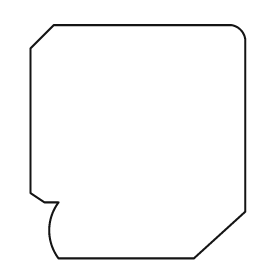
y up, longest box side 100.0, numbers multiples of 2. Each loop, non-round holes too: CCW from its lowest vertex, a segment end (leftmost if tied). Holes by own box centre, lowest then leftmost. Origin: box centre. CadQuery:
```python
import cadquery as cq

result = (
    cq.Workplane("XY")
    .moveTo(-34.0, -50.0)
    .lineTo(24.0, -50.0)
    .lineTo(46.0, -30.0)
    .lineTo(46.0, 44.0)
    .threePointArc((44.0, 48.0), (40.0, 50.0))
    .lineTo(-36.0, 50.0)
    .lineTo(-46.0, 40.0)
    .lineTo(-46.0, -22.0)
    .lineTo(-40.0, -26.0)
    .lineTo(-34.0, -26.0)
    .threePointArc((-38.0, -38.0), (-34.0, -50.0))
    .close()
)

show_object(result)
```